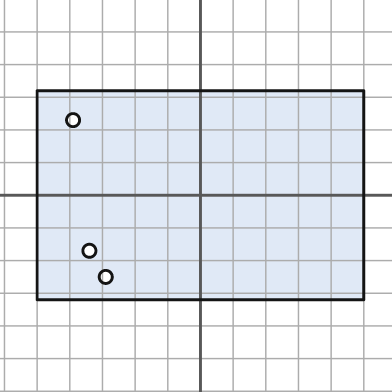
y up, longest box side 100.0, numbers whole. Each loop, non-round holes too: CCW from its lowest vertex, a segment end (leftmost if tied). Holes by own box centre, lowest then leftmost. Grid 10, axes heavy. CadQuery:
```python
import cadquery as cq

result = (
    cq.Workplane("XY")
    .moveTo(-50.0, -32.0)
    .lineTo(50.0, -32.0)
    .lineTo(50.0, 32.0)
    .lineTo(-50.0, 32.0)
    .close()
    .moveTo(-29.0, -25.0)
    .circle(2.0)
    .moveTo(-34.0, -17.0)
    .circle(2.0)
    .moveTo(-39.0, 23.0)
    .circle(2.0)
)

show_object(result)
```